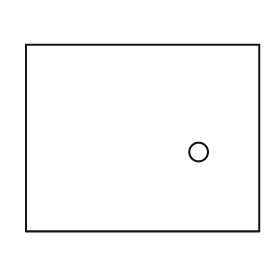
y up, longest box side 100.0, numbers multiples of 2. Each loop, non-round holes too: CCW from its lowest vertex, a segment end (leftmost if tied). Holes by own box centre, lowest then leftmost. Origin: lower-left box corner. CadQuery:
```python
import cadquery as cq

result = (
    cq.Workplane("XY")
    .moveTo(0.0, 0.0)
    .lineTo(100.0, 0.0)
    .lineTo(100.0, 80.0)
    .lineTo(0.0, 80.0)
    .close()
    .moveTo(74.0, 34.0)
    .circle(4.0)
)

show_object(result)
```